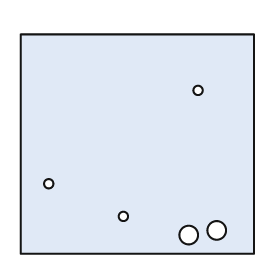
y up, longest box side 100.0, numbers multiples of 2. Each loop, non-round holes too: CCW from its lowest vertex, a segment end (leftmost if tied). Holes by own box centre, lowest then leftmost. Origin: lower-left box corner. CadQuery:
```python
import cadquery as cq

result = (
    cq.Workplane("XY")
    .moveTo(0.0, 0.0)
    .lineTo(100.0, 0.0)
    .lineTo(100.0, 94.0)
    .lineTo(0.0, 94.0)
    .close()
    .moveTo(72.0, 8.0)
    .circle(4.0)
    .moveTo(84.0, 10.0)
    .circle(4.0)
    .moveTo(44.0, 16.0)
    .circle(2.0)
    .moveTo(12.0, 30.0)
    .circle(2.0)
    .moveTo(76.0, 70.0)
    .circle(2.0)
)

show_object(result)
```